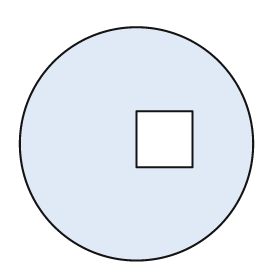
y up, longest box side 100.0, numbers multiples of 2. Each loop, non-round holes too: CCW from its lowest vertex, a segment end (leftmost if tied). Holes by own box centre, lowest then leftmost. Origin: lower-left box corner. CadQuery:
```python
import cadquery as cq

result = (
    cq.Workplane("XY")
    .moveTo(50.0, 50.0)
    .circle(50.0)
    .moveTo(50.0, 40.0)
    .lineTo(74.0, 40.0)
    .lineTo(74.0, 64.0)
    .lineTo(50.0, 64.0)
    .close()
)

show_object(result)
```